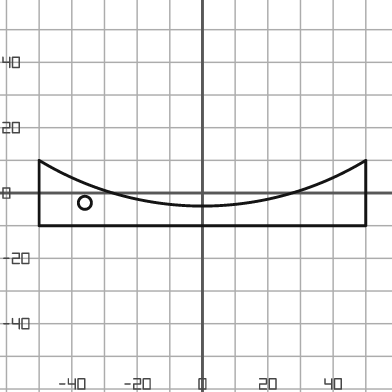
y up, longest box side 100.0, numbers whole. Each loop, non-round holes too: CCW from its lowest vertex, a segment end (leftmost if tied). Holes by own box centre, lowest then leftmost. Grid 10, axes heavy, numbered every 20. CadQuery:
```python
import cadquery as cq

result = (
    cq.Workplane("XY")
    .moveTo(-50.0, -10.0)
    .lineTo(50.0, -10.0)
    .lineTo(50.0, 10.0)
    .threePointArc((0.0, -4.0), (-50.0, 10.0))
    .close()
    .moveTo(-36.0, -3.0)
    .circle(2.0)
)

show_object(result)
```